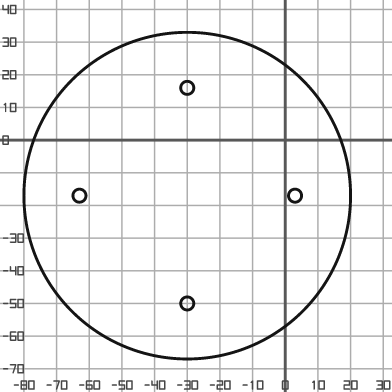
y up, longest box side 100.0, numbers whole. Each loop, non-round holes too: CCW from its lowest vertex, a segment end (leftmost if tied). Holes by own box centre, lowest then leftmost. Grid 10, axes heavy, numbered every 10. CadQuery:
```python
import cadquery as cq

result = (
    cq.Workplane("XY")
    .moveTo(-30.0, -17.0)
    .circle(50.0)
    .moveTo(-30.0, -50.0)
    .circle(2.0)
    .moveTo(-63.0, -17.0)
    .circle(2.0)
    .moveTo(3.0, -17.0)
    .circle(2.0)
    .moveTo(-30.0, 16.0)
    .circle(2.0)
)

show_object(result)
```